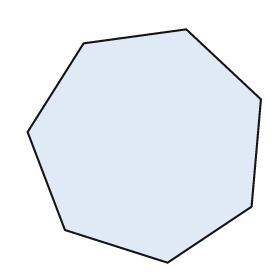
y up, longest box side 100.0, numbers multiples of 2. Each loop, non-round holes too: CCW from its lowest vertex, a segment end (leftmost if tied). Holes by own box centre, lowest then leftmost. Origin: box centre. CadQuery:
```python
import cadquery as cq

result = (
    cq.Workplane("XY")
    .moveTo(10.0, -50.0)
    .lineTo(46.0, -26.0)
    .lineTo(50.0, 20.0)
    .lineTo(18.0, 50.0)
    .lineTo(-26.0, 44.0)
    .lineTo(-50.0, 6.0)
    .lineTo(-34.0, -36.0)
    .close()
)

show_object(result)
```